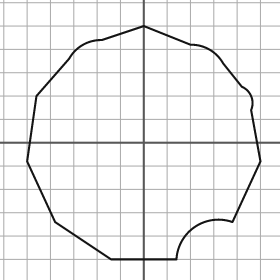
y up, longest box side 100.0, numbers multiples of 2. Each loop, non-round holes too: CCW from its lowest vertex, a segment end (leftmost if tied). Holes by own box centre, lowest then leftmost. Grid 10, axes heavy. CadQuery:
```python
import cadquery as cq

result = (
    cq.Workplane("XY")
    .moveTo(-14.0, -50.0)
    .lineTo(14.0, -50.0)
    .threePointArc((22.0, -36.0), (38.0, -34.0))
    .lineTo(50.0, -8.0)
    .lineTo(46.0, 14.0)
    .threePointArc((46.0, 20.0), (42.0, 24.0))
    .lineTo(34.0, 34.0)
    .threePointArc((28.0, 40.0), (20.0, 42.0))
    .lineTo(0.0, 50.0)
    .lineTo(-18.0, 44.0)
    .threePointArc((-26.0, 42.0), (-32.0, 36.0))
    .lineTo(-46.0, 20.0)
    .lineTo(-50.0, -8.0)
    .lineTo(-38.0, -34.0)
    .close()
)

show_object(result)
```